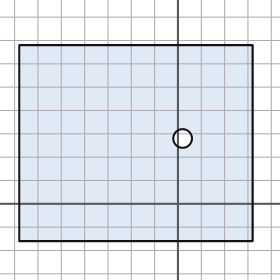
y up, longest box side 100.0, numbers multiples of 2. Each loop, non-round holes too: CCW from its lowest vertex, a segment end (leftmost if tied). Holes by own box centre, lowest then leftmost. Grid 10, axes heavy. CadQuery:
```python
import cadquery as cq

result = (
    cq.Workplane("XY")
    .moveTo(-68.0, -16.0)
    .lineTo(32.0, -16.0)
    .lineTo(32.0, 68.0)
    .lineTo(-68.0, 68.0)
    .close()
    .moveTo(2.0, 28.0)
    .circle(4.0)
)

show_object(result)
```